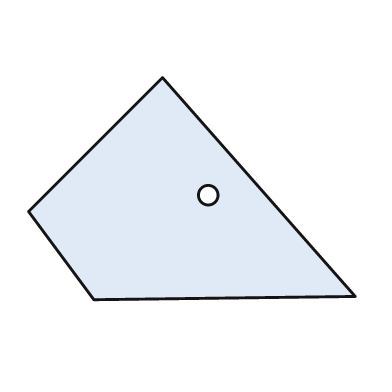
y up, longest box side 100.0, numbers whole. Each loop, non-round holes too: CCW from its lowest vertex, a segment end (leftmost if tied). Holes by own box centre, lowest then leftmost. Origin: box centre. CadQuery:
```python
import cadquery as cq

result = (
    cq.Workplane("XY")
    .moveTo(-30.0, -34.0)
    .lineTo(50.0, -33.0)
    .lineTo(-9.0, 34.0)
    .lineTo(-50.0, -7.0)
    .close()
    .moveTo(5.0, -2.0)
    .circle(3.0)
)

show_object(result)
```